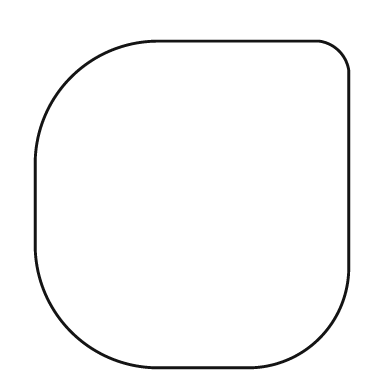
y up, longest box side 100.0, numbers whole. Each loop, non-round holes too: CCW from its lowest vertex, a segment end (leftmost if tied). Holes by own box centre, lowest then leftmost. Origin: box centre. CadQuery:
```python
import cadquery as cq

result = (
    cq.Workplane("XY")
    .moveTo(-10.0, -50.0)
    .lineTo(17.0, -50.0)
    .threePointArc((39.0, -41.0), (48.0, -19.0))
    .lineTo(48.0, 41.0)
    .threePointArc((45.0, 47.0), (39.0, 50.0))
    .lineTo(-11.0, 50.0)
    .threePointArc((-37.0, 39.0), (-48.0, 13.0))
    .lineTo(-48.0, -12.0)
    .threePointArc((-37.0, -39.0), (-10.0, -50.0))
    .close()
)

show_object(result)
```